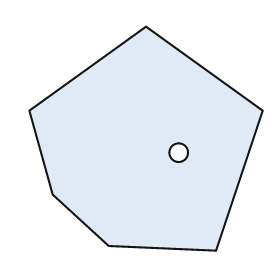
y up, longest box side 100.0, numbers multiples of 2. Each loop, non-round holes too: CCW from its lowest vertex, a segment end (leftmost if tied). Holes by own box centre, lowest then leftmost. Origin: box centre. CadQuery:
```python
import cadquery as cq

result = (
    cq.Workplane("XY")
    .moveTo(30.0, -48.0)
    .lineTo(50.0, 12.0)
    .lineTo(0.0, 48.0)
    .lineTo(-50.0, 12.0)
    .lineTo(-40.0, -24.0)
    .lineTo(-16.0, -46.0)
    .close()
    .moveTo(14.0, -6.0)
    .circle(4.0)
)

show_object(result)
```